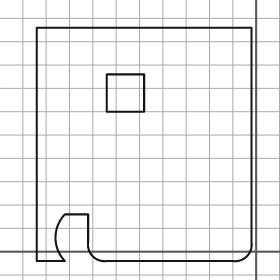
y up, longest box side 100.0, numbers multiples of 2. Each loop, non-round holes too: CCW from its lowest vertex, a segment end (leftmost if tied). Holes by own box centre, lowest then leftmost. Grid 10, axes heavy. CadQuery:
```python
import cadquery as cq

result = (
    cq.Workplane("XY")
    .moveTo(-94.0, -4.0)
    .lineTo(-82.0, -4.0)
    .threePointArc((-86.0, 6.0), (-82.0, 16.0))
    .lineTo(-72.0, 16.0)
    .lineTo(-72.0, 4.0)
    .threePointArc((-70.0, -2.0), (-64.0, -4.0))
    .lineTo(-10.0, -4.0)
    .threePointArc((-4.0, -2.0), (-2.0, 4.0))
    .lineTo(-2.0, 96.0)
    .lineTo(-94.0, 96.0)
    .close()
    .moveTo(-64.0, 60.0)
    .lineTo(-48.0, 60.0)
    .lineTo(-48.0, 76.0)
    .lineTo(-64.0, 76.0)
    .close()
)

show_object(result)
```